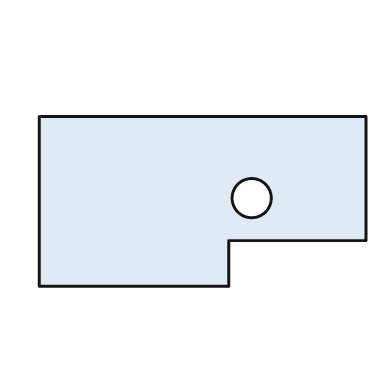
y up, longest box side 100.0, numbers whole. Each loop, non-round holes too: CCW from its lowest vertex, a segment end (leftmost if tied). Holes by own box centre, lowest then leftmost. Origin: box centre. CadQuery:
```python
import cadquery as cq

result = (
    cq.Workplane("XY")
    .moveTo(-50.0, -26.0)
    .lineTo(8.0, -26.0)
    .lineTo(8.0, -12.0)
    .lineTo(50.0, -12.0)
    .lineTo(50.0, 26.0)
    .lineTo(-50.0, 26.0)
    .close()
    .moveTo(15.0, 1.0)
    .circle(6.0)
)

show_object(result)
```